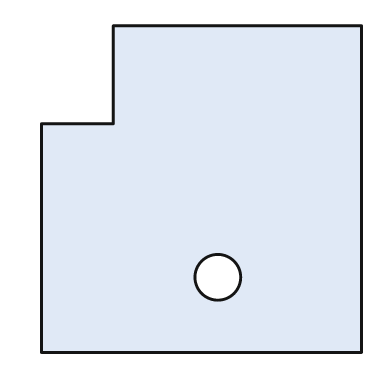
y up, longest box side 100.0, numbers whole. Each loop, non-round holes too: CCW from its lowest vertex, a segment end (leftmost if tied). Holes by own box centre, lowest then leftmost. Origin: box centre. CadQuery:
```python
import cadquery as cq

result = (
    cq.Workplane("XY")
    .moveTo(-49.0, -50.0)
    .lineTo(49.0, -50.0)
    .lineTo(49.0, 50.0)
    .lineTo(-27.0, 50.0)
    .lineTo(-27.0, 20.0)
    .lineTo(-49.0, 20.0)
    .close()
    .moveTo(5.0, -27.0)
    .circle(7.0)
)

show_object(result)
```